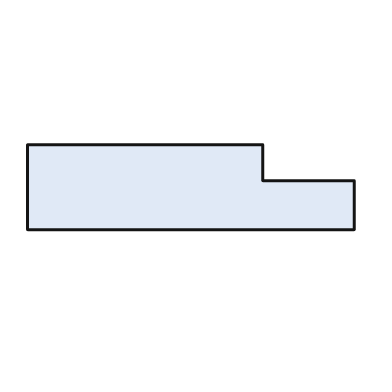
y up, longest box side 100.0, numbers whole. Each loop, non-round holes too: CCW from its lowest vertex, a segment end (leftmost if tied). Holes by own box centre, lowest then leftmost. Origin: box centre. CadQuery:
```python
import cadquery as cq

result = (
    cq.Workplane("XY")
    .moveTo(-50.0, -13.0)
    .lineTo(50.0, -13.0)
    .lineTo(50.0, 2.0)
    .lineTo(22.0, 2.0)
    .lineTo(22.0, 13.0)
    .lineTo(-50.0, 13.0)
    .close()
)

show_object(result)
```